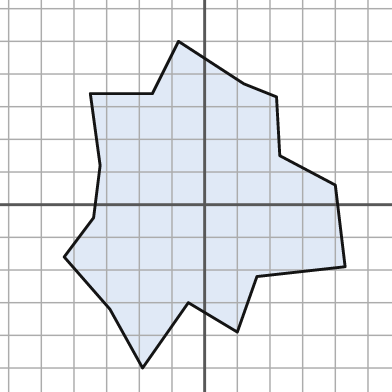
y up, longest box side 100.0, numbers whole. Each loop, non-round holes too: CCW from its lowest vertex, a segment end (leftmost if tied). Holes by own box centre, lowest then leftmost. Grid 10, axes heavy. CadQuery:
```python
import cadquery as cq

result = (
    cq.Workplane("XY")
    .moveTo(-19.0, -50.0)
    .lineTo(-5.0, -30.0)
    .lineTo(10.0, -39.0)
    .lineTo(16.0, -22.0)
    .lineTo(43.0, -19.0)
    .lineTo(40.0, 6.0)
    .lineTo(23.0, 15.0)
    .lineTo(22.0, 33.0)
    .lineTo(12.0, 37.0)
    .lineTo(-8.0, 50.0)
    .lineTo(-16.0, 34.0)
    .lineTo(-35.0, 34.0)
    .lineTo(-32.0, 12.0)
    .lineTo(-34.0, -4.0)
    .lineTo(-43.0, -16.0)
    .lineTo(-29.0, -32.0)
    .close()
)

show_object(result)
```